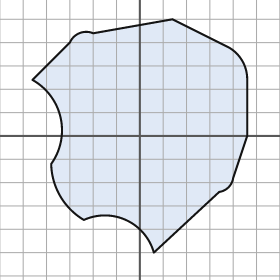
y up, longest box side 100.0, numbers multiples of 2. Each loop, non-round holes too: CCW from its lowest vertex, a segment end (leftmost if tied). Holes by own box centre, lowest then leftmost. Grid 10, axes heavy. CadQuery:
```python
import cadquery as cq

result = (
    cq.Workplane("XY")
    .moveTo(6.0, -50.0)
    .lineTo(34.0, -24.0)
    .threePointArc((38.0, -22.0), (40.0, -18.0))
    .lineTo(46.0, 0.0)
    .lineTo(46.0, 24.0)
    .threePointArc((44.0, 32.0), (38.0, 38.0))
    .lineTo(14.0, 50.0)
    .lineTo(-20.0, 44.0)
    .threePointArc((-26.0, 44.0), (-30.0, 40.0))
    .lineTo(-46.0, 24.0)
    .threePointArc((-34.0, 8.0), (-38.0, -12.0))
    .threePointArc((-34.0, -26.0), (-24.0, -36.0))
    .threePointArc((-6.0, -36.0), (6.0, -50.0))
    .close()
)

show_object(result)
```